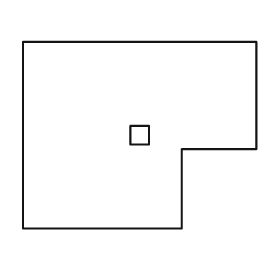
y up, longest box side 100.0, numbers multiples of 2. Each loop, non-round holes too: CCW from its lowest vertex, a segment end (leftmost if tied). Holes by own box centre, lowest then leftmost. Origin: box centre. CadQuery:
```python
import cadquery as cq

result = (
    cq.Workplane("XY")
    .moveTo(-50.0, -40.0)
    .lineTo(18.0, -40.0)
    .lineTo(18.0, -6.0)
    .lineTo(50.0, -6.0)
    .lineTo(50.0, 40.0)
    .lineTo(-50.0, 40.0)
    .close()
    .moveTo(-4.0, -4.0)
    .lineTo(4.0, -4.0)
    .lineTo(4.0, 4.0)
    .lineTo(-4.0, 4.0)
    .close()
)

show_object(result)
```